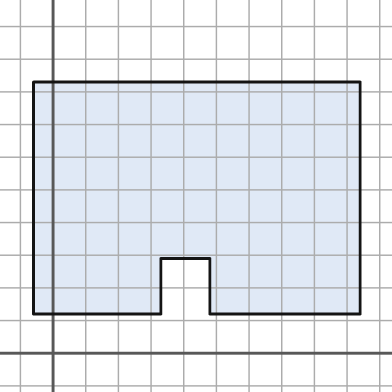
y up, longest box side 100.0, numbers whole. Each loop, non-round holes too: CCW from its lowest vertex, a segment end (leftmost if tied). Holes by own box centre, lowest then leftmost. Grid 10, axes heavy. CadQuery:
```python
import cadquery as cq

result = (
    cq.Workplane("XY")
    .moveTo(-6.0, 12.0)
    .lineTo(33.0, 12.0)
    .lineTo(33.0, 29.0)
    .lineTo(48.0, 29.0)
    .lineTo(48.0, 12.0)
    .lineTo(94.0, 12.0)
    .lineTo(94.0, 83.0)
    .lineTo(-6.0, 83.0)
    .close()
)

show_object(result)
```